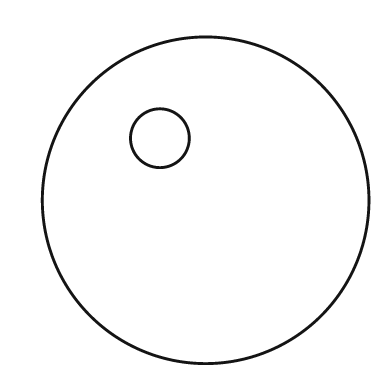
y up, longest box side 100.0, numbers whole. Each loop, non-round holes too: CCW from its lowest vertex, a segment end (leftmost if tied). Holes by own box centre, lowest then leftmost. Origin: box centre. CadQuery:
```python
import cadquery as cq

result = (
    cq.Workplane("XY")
    .moveTo(0.0, 0.0)
    .circle(50.0)
    .moveTo(-14.0, 19.0)
    .circle(9.0)
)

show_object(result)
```